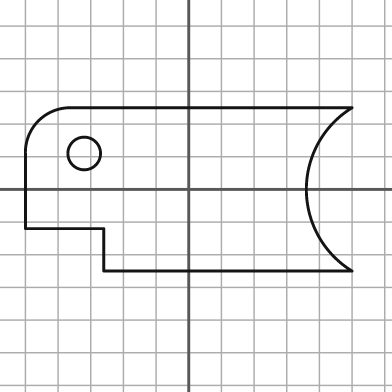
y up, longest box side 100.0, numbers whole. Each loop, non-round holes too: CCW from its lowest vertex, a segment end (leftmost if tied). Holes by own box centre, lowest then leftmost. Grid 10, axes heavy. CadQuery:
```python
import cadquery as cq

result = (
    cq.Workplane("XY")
    .moveTo(-26.0, -25.0)
    .lineTo(50.0, -25.0)
    .threePointArc((36.0, 0.0), (50.0, 25.0))
    .lineTo(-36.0, 25.0)
    .threePointArc((-46.0, 21.0), (-50.0, 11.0))
    .lineTo(-50.0, -12.0)
    .lineTo(-26.0, -12.0)
    .close()
    .moveTo(-32.0, 11.0)
    .circle(5.0)
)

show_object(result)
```